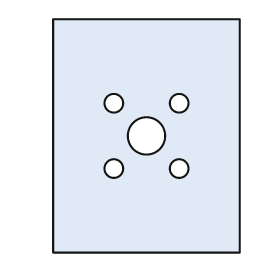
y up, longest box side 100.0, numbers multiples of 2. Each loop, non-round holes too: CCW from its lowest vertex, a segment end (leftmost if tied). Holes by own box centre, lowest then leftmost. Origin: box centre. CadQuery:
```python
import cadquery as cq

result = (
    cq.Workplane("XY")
    .moveTo(-40.0, -50.0)
    .lineTo(40.0, -50.0)
    .lineTo(40.0, 50.0)
    .lineTo(-40.0, 50.0)
    .close()
    .moveTo(-14.0, -14.0)
    .circle(4.0)
    .moveTo(14.0, -14.0)
    .circle(4.0)
    .moveTo(0.0, 0.0)
    .circle(8.0)
    .moveTo(-14.0, 14.0)
    .circle(4.0)
    .moveTo(14.0, 14.0)
    .circle(4.0)
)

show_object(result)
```